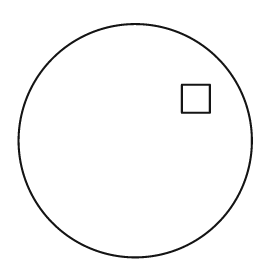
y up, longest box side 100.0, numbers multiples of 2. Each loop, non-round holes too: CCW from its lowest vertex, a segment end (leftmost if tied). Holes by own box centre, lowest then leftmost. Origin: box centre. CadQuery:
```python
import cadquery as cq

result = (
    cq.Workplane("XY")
    .moveTo(0.0, 0.0)
    .circle(50.0)
    .moveTo(20.0, 12.0)
    .lineTo(32.0, 12.0)
    .lineTo(32.0, 24.0)
    .lineTo(20.0, 24.0)
    .close()
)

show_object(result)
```